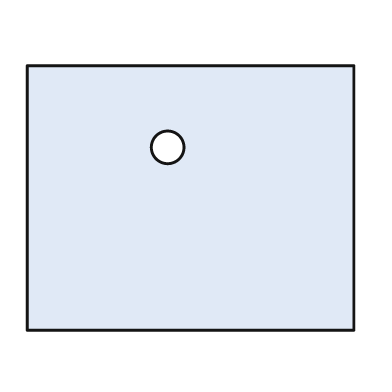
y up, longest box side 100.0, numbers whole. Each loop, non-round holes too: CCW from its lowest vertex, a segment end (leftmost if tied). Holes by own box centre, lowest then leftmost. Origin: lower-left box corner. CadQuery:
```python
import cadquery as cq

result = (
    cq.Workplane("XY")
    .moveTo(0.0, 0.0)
    .lineTo(100.0, 0.0)
    .lineTo(100.0, 81.0)
    .lineTo(0.0, 81.0)
    .close()
    .moveTo(43.0, 56.0)
    .circle(5.0)
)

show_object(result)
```